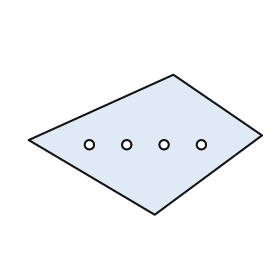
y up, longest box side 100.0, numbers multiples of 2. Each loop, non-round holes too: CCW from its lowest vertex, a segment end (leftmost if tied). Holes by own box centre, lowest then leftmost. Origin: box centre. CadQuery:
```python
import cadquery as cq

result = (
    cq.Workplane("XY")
    .moveTo(4.0, -30.0)
    .lineTo(50.0, 4.0)
    .lineTo(12.0, 30.0)
    .lineTo(-50.0, 2.0)
    .close()
    .moveTo(-24.0, 0.0)
    .circle(2.0)
    .moveTo(-8.0, 0.0)
    .circle(2.0)
    .moveTo(8.0, 0.0)
    .circle(2.0)
    .moveTo(24.0, 0.0)
    .circle(2.0)
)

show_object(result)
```